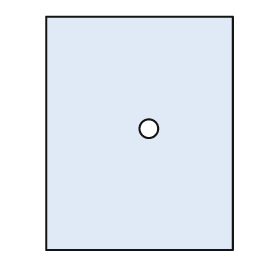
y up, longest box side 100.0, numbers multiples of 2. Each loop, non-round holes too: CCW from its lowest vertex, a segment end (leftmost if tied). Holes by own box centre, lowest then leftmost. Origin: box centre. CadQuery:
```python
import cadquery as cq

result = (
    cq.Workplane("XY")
    .moveTo(-40.0, -50.0)
    .lineTo(40.0, -50.0)
    .lineTo(40.0, 50.0)
    .lineTo(-40.0, 50.0)
    .close()
    .moveTo(4.0, 2.0)
    .circle(4.0)
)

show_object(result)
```